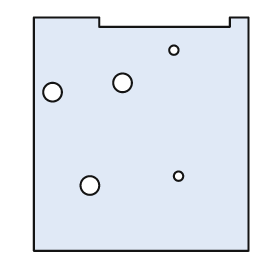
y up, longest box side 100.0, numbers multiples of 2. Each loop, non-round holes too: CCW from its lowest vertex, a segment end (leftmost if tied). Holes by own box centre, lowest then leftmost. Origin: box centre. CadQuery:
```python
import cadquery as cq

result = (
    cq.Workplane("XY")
    .moveTo(-46.0, -50.0)
    .lineTo(46.0, -50.0)
    .lineTo(46.0, 50.0)
    .lineTo(38.0, 50.0)
    .lineTo(38.0, 46.0)
    .lineTo(-18.0, 46.0)
    .lineTo(-18.0, 50.0)
    .lineTo(-46.0, 50.0)
    .close()
    .moveTo(-22.0, -22.0)
    .circle(4.0)
    .moveTo(16.0, -18.0)
    .circle(2.0)
    .moveTo(-38.0, 18.0)
    .circle(4.0)
    .moveTo(-8.0, 22.0)
    .circle(4.0)
    .moveTo(14.0, 36.0)
    .circle(2.0)
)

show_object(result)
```